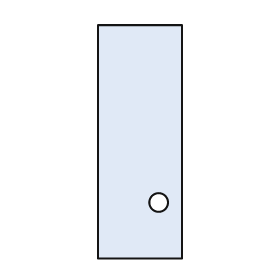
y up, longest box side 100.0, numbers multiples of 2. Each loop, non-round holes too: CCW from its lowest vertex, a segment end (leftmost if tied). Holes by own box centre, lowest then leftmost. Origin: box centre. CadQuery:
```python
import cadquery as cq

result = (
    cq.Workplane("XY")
    .moveTo(-18.0, -50.0)
    .lineTo(18.0, -50.0)
    .lineTo(18.0, 50.0)
    .lineTo(-18.0, 50.0)
    .close()
    .moveTo(8.0, -26.0)
    .circle(4.0)
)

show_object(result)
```